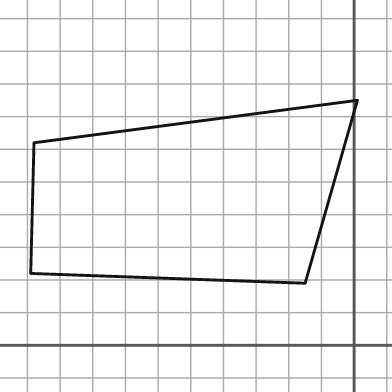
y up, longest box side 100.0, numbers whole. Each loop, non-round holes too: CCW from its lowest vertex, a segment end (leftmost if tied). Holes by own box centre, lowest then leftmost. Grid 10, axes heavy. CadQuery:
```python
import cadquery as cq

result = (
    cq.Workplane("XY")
    .moveTo(-15.0, 19.0)
    .lineTo(1.0, 75.0)
    .lineTo(-98.0, 62.0)
    .lineTo(-99.0, 22.0)
    .close()
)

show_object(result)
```